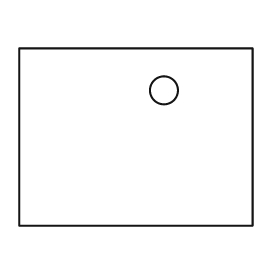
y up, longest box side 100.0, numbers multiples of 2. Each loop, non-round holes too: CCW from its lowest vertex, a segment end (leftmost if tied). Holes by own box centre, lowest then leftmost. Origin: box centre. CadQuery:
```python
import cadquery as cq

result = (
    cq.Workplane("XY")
    .moveTo(-50.0, -38.0)
    .lineTo(50.0, -38.0)
    .lineTo(50.0, 38.0)
    .lineTo(-50.0, 38.0)
    .close()
    .moveTo(12.0, 20.0)
    .circle(6.0)
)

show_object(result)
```